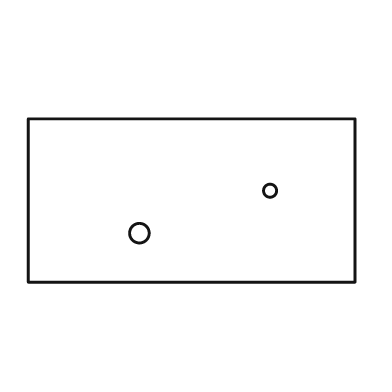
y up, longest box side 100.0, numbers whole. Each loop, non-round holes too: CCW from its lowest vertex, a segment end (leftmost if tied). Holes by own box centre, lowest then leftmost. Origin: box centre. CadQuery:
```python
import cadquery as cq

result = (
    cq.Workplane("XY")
    .moveTo(-50.0, -25.0)
    .lineTo(50.0, -25.0)
    .lineTo(50.0, 25.0)
    .lineTo(-50.0, 25.0)
    .close()
    .moveTo(-16.0, -10.0)
    .circle(3.0)
    .moveTo(24.0, 3.0)
    .circle(2.0)
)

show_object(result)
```